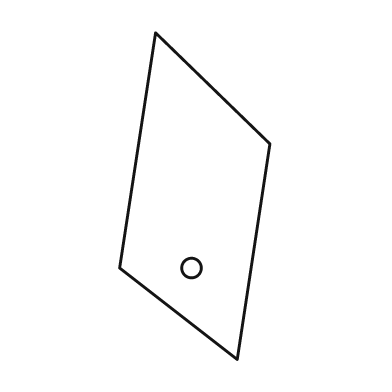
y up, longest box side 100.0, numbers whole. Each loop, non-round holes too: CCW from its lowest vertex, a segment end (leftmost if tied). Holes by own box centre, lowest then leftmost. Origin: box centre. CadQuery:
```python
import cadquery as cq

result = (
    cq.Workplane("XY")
    .moveTo(13.0, -50.0)
    .lineTo(23.0, 16.0)
    .lineTo(-12.0, 50.0)
    .lineTo(-23.0, -22.0)
    .close()
    .moveTo(-1.0, -22.0)
    .circle(3.0)
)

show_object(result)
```